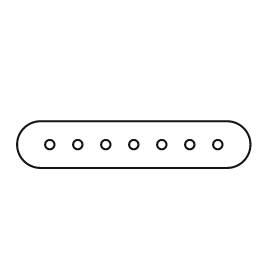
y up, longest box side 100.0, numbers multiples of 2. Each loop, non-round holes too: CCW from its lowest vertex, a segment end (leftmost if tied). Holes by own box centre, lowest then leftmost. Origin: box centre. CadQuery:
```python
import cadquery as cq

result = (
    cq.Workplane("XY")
    .moveTo(-40.0, -10.0)
    .lineTo(40.0, -10.0)
    .threePointArc((50.0, 0.0), (40.0, 10.0))
    .lineTo(-40.0, 10.0)
    .threePointArc((-50.0, 0.0), (-40.0, -10.0))
    .close()
    .moveTo(-36.0, 0.0)
    .circle(2.0)
    .moveTo(-24.0, 0.0)
    .circle(2.0)
    .moveTo(-12.0, 0.0)
    .circle(2.0)
    .moveTo(0.0, 0.0)
    .circle(2.0)
    .moveTo(12.0, 0.0)
    .circle(2.0)
    .moveTo(24.0, 0.0)
    .circle(2.0)
    .moveTo(36.0, 0.0)
    .circle(2.0)
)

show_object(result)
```